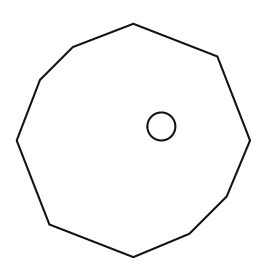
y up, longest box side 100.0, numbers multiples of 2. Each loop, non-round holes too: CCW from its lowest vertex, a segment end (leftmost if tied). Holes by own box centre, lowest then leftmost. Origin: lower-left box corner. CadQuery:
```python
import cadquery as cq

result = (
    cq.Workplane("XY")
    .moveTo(50.0, 0.0)
    .lineTo(74.0, 10.0)
    .lineTo(90.0, 26.0)
    .lineTo(100.0, 50.0)
    .lineTo(86.0, 86.0)
    .lineTo(50.0, 100.0)
    .lineTo(24.0, 90.0)
    .lineTo(10.0, 76.0)
    .lineTo(0.0, 50.0)
    .lineTo(14.0, 14.0)
    .close()
    .moveTo(62.0, 56.0)
    .circle(6.0)
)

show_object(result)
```